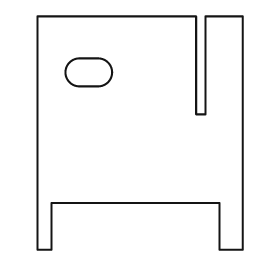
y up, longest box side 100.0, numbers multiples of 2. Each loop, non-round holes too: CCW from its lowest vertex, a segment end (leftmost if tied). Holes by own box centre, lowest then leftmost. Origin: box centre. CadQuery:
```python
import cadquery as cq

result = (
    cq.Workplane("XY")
    .moveTo(-44.0, -50.0)
    .lineTo(-38.0, -50.0)
    .lineTo(-38.0, -30.0)
    .lineTo(34.0, -30.0)
    .lineTo(34.0, -50.0)
    .lineTo(44.0, -50.0)
    .lineTo(44.0, 50.0)
    .lineTo(28.0, 50.0)
    .lineTo(28.0, 8.0)
    .lineTo(24.0, 8.0)
    .lineTo(24.0, 50.0)
    .lineTo(-44.0, 50.0)
    .close()
    .moveTo(-26.0, 20.0)
    .lineTo(-18.0, 20.0)
    .threePointArc((-12.0, 26.0), (-18.0, 32.0))
    .lineTo(-26.0, 32.0)
    .threePointArc((-32.0, 26.0), (-26.0, 20.0))
    .close()
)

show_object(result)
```